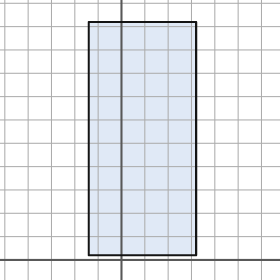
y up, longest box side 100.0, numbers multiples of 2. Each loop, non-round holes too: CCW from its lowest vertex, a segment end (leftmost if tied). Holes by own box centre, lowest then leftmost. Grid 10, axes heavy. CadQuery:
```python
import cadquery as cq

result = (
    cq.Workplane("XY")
    .moveTo(-14.0, 2.0)
    .lineTo(32.0, 2.0)
    .lineTo(32.0, 102.0)
    .lineTo(-14.0, 102.0)
    .close()
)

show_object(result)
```